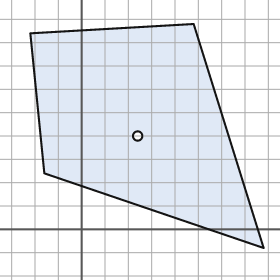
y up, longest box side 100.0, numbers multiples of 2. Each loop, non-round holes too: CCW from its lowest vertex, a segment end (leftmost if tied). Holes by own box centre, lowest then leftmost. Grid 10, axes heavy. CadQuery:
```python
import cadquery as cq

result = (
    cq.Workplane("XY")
    .moveTo(78.0, -8.0)
    .lineTo(48.0, 88.0)
    .lineTo(-22.0, 84.0)
    .lineTo(-16.0, 24.0)
    .close()
    .moveTo(24.0, 40.0)
    .circle(2.0)
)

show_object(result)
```